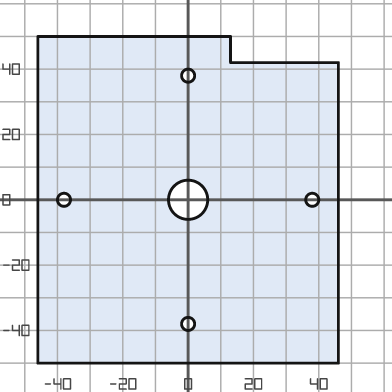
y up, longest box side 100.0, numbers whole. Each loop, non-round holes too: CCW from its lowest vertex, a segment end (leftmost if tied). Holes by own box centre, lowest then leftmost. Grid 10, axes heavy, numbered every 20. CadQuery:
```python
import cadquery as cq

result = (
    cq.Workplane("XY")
    .moveTo(-46.0, -50.0)
    .lineTo(46.0, -50.0)
    .lineTo(46.0, 42.0)
    .lineTo(13.0, 42.0)
    .lineTo(13.0, 50.0)
    .lineTo(-46.0, 50.0)
    .close()
    .moveTo(0.0, -38.0)
    .circle(2.0)
    .moveTo(-38.0, 0.0)
    .circle(2.0)
    .moveTo(0.0, 0.0)
    .circle(6.0)
    .moveTo(38.0, 0.0)
    .circle(2.0)
    .moveTo(0.0, 38.0)
    .circle(2.0)
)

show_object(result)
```